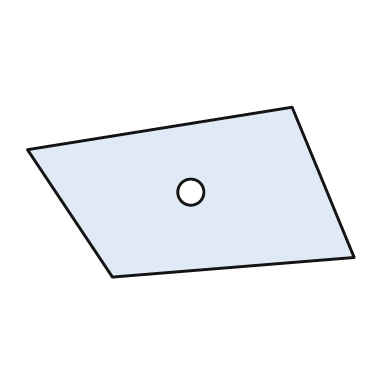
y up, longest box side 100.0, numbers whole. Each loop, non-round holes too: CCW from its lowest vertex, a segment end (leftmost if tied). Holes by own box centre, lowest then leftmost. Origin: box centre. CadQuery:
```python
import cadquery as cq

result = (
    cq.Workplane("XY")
    .moveTo(-24.0, -26.0)
    .lineTo(50.0, -20.0)
    .lineTo(31.0, 26.0)
    .lineTo(-50.0, 13.0)
    .close()
    .moveTo(0.0, 0.0)
    .circle(4.0)
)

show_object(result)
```